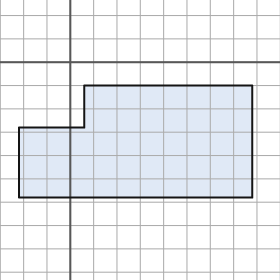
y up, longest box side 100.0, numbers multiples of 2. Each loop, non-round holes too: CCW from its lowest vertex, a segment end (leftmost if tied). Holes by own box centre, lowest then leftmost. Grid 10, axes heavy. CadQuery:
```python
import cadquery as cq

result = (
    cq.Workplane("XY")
    .moveTo(-22.0, -58.0)
    .lineTo(78.0, -58.0)
    .lineTo(78.0, -10.0)
    .lineTo(6.0, -10.0)
    .lineTo(6.0, -28.0)
    .lineTo(-22.0, -28.0)
    .close()
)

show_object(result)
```